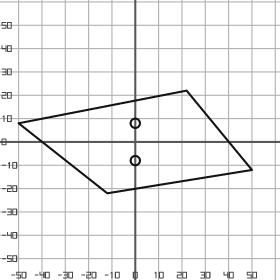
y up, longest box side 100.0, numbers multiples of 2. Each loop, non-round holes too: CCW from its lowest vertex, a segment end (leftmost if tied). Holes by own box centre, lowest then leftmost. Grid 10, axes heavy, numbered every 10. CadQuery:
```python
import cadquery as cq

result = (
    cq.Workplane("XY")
    .moveTo(-12.0, -22.0)
    .lineTo(50.0, -12.0)
    .lineTo(22.0, 22.0)
    .lineTo(-50.0, 8.0)
    .close()
    .moveTo(0.0, -8.0)
    .circle(2.0)
    .moveTo(0.0, 8.0)
    .circle(2.0)
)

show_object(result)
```